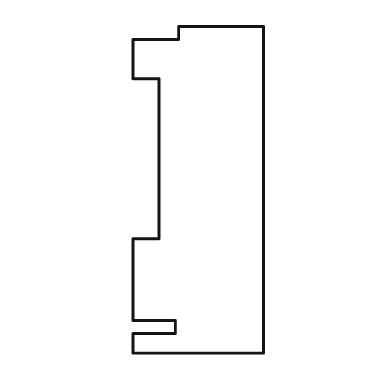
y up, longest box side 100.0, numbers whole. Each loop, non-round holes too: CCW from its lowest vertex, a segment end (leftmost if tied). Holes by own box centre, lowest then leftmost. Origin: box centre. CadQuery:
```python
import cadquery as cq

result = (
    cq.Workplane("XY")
    .moveTo(-20.0, -50.0)
    .lineTo(20.0, -50.0)
    .lineTo(20.0, 50.0)
    .lineTo(-6.0, 50.0)
    .lineTo(-6.0, 46.0)
    .lineTo(-20.0, 46.0)
    .lineTo(-20.0, 34.0)
    .lineTo(-12.0, 34.0)
    .lineTo(-12.0, -15.0)
    .lineTo(-20.0, -15.0)
    .lineTo(-20.0, -40.0)
    .lineTo(-7.0, -40.0)
    .lineTo(-7.0, -44.0)
    .lineTo(-20.0, -44.0)
    .close()
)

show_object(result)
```